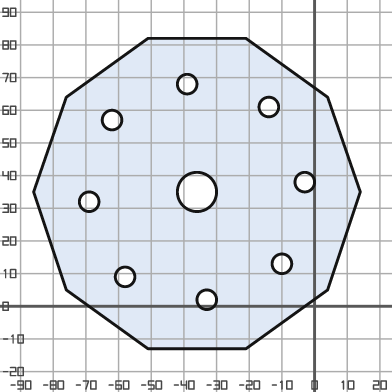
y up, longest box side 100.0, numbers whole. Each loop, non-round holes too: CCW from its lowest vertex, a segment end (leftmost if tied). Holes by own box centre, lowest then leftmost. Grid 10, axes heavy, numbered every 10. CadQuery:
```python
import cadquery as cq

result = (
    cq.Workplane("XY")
    .moveTo(-51.0, -13.0)
    .lineTo(-21.0, -13.0)
    .lineTo(4.0, 5.0)
    .lineTo(14.0, 35.0)
    .lineTo(4.0, 64.0)
    .lineTo(-21.0, 82.0)
    .lineTo(-51.0, 82.0)
    .lineTo(-76.0, 64.0)
    .lineTo(-86.0, 35.0)
    .lineTo(-76.0, 5.0)
    .close()
    .moveTo(-33.0, 2.0)
    .circle(3.0)
    .moveTo(-58.0, 9.0)
    .circle(3.0)
    .moveTo(-10.0, 13.0)
    .circle(3.0)
    .moveTo(-69.0, 32.0)
    .circle(3.0)
    .moveTo(-36.0, 35.0)
    .circle(6.0)
    .moveTo(-3.0, 38.0)
    .circle(3.0)
    .moveTo(-62.0, 57.0)
    .circle(3.0)
    .moveTo(-14.0, 61.0)
    .circle(3.0)
    .moveTo(-39.0, 68.0)
    .circle(3.0)
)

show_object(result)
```